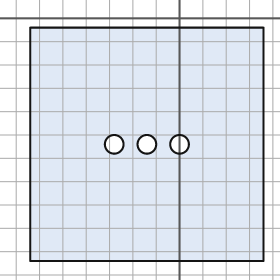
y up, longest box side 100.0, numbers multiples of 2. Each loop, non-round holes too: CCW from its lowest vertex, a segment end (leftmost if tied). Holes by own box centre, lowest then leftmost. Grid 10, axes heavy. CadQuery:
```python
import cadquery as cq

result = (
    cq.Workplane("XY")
    .moveTo(-64.0, -104.0)
    .lineTo(36.0, -104.0)
    .lineTo(36.0, -4.0)
    .lineTo(-64.0, -4.0)
    .close()
    .moveTo(-28.0, -54.0)
    .circle(4.0)
    .moveTo(-14.0, -54.0)
    .circle(4.0)
    .moveTo(0.0, -54.0)
    .circle(4.0)
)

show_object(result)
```